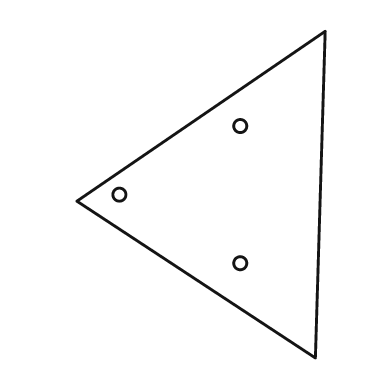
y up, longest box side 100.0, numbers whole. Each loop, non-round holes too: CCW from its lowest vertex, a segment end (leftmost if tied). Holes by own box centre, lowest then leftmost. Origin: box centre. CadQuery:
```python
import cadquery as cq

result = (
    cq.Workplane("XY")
    .moveTo(35.0, -50.0)
    .lineTo(38.0, 50.0)
    .lineTo(-38.0, -2.0)
    .close()
    .moveTo(12.0, -21.0)
    .circle(2.0)
    .moveTo(-25.0, 0.0)
    .circle(2.0)
    .moveTo(12.0, 21.0)
    .circle(2.0)
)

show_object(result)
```